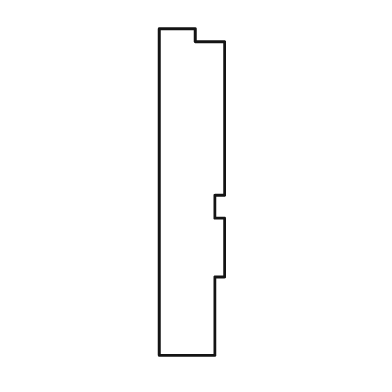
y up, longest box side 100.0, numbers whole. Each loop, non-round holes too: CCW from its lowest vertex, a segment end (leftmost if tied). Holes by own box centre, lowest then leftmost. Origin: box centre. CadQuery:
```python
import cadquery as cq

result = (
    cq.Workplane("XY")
    .moveTo(-10.0, -50.0)
    .lineTo(7.0, -50.0)
    .lineTo(7.0, -26.0)
    .lineTo(10.0, -26.0)
    .lineTo(10.0, -8.0)
    .lineTo(7.0, -8.0)
    .lineTo(7.0, -1.0)
    .lineTo(10.0, -1.0)
    .lineTo(10.0, 46.0)
    .lineTo(1.0, 46.0)
    .lineTo(1.0, 50.0)
    .lineTo(-10.0, 50.0)
    .close()
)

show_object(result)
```